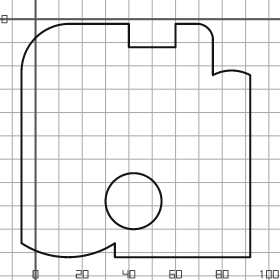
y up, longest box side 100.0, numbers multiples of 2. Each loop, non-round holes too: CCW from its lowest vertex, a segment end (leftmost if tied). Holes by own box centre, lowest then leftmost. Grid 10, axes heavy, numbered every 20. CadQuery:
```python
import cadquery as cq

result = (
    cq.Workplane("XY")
    .moveTo(34.0, -102.0)
    .lineTo(92.0, -102.0)
    .lineTo(92.0, -24.0)
    .threePointArc((84.0, -22.0), (76.0, -24.0))
    .lineTo(76.0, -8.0)
    .threePointArc((74.0, -4.0), (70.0, -2.0))
    .lineTo(60.0, -2.0)
    .lineTo(60.0, -12.0)
    .lineTo(40.0, -12.0)
    .lineTo(40.0, -2.0)
    .lineTo(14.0, -2.0)
    .threePointArc((0.0, -8.0), (-6.0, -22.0))
    .lineTo(-6.0, -96.0)
    .threePointArc((14.0, -102.0), (34.0, -96.0))
    .close()
    .moveTo(42.0, -78.0)
    .circle(12.0)
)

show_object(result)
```